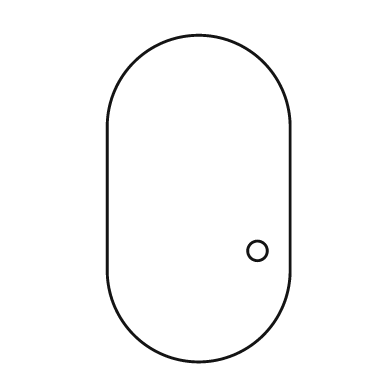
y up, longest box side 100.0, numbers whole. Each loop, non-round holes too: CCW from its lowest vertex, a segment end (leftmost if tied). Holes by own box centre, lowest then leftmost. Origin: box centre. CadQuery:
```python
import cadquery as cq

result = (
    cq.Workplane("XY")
    .moveTo(-28.0, -22.0)
    .threePointArc((0.0, -50.0), (28.0, -22.0))
    .lineTo(28.0, 22.0)
    .threePointArc((0.0, 50.0), (-28.0, 22.0))
    .close()
    .moveTo(18.0, -16.0)
    .circle(3.0)
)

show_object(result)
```